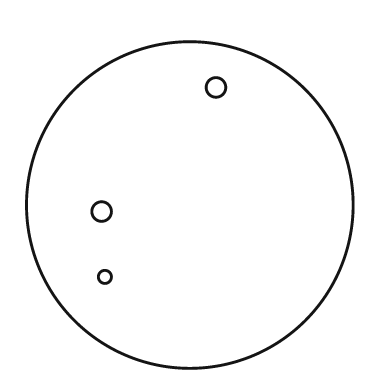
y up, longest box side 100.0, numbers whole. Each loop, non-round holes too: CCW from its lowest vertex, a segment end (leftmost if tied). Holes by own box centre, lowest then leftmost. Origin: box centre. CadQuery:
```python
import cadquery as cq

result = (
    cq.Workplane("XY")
    .moveTo(0.0, 0.0)
    .circle(50.0)
    .moveTo(-26.0, -22.0)
    .circle(2.0)
    .moveTo(-27.0, -2.0)
    .circle(3.0)
    .moveTo(8.0, 36.0)
    .circle(3.0)
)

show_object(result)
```